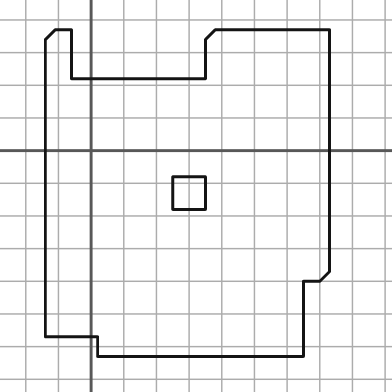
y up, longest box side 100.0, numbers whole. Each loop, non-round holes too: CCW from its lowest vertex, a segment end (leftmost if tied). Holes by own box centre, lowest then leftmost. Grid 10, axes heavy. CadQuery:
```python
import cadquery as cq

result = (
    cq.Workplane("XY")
    .moveTo(2.0, -63.0)
    .lineTo(65.0, -63.0)
    .lineTo(65.0, -40.0)
    .lineTo(70.0, -40.0)
    .lineTo(73.0, -37.0)
    .lineTo(73.0, 37.0)
    .lineTo(38.0, 37.0)
    .lineTo(35.0, 34.0)
    .lineTo(35.0, 22.0)
    .lineTo(-6.0, 22.0)
    .lineTo(-6.0, 37.0)
    .lineTo(-11.0, 37.0)
    .lineTo(-14.0, 34.0)
    .lineTo(-14.0, -57.0)
    .lineTo(2.0, -57.0)
    .close()
    .moveTo(25.0, -18.0)
    .lineTo(35.0, -18.0)
    .lineTo(35.0, -8.0)
    .lineTo(25.0, -8.0)
    .close()
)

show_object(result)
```